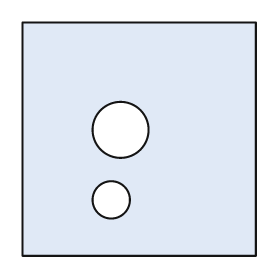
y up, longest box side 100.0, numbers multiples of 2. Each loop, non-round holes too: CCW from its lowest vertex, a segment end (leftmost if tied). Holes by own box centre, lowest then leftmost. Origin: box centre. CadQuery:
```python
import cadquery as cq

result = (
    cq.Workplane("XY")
    .moveTo(-50.0, -50.0)
    .lineTo(50.0, -50.0)
    .lineTo(50.0, 50.0)
    .lineTo(-50.0, 50.0)
    .close()
    .moveTo(-12.0, -26.0)
    .circle(8.0)
    .moveTo(-8.0, 4.0)
    .circle(12.0)
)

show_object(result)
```